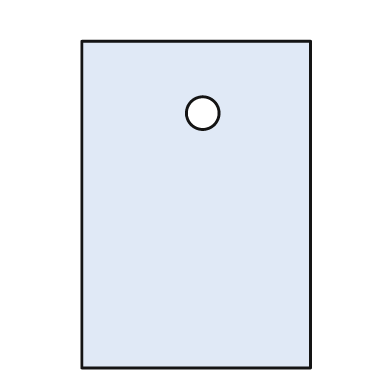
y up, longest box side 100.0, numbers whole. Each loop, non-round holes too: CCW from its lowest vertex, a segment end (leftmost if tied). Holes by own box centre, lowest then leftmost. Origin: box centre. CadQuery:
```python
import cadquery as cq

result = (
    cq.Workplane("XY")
    .moveTo(-35.0, -50.0)
    .lineTo(35.0, -50.0)
    .lineTo(35.0, 50.0)
    .lineTo(-35.0, 50.0)
    .close()
    .moveTo(2.0, 28.0)
    .circle(5.0)
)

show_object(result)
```